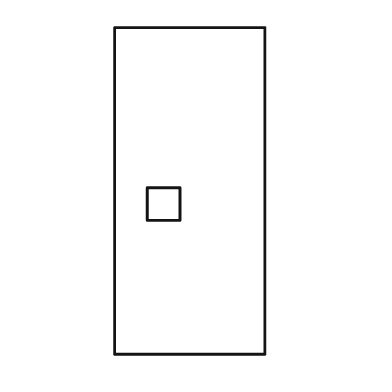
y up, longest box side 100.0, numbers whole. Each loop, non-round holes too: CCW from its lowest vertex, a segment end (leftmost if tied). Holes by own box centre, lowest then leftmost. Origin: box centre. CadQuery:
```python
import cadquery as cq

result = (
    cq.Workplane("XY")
    .moveTo(-23.0, -50.0)
    .lineTo(23.0, -50.0)
    .lineTo(23.0, 50.0)
    .lineTo(-23.0, 50.0)
    .close()
    .moveTo(-13.0, -9.0)
    .lineTo(-3.0, -9.0)
    .lineTo(-3.0, 1.0)
    .lineTo(-13.0, 1.0)
    .close()
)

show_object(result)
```